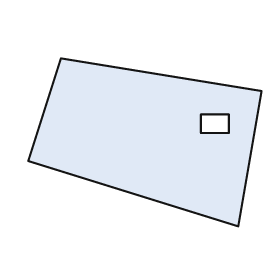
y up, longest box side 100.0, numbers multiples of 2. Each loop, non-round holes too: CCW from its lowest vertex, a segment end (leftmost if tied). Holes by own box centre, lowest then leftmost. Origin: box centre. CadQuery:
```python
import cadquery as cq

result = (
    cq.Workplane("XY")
    .moveTo(40.0, -36.0)
    .lineTo(50.0, 22.0)
    .lineTo(-36.0, 36.0)
    .lineTo(-50.0, -8.0)
    .close()
    .moveTo(24.0, 4.0)
    .lineTo(36.0, 4.0)
    .lineTo(36.0, 12.0)
    .lineTo(24.0, 12.0)
    .close()
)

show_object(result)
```